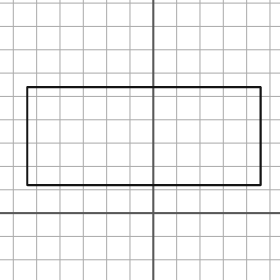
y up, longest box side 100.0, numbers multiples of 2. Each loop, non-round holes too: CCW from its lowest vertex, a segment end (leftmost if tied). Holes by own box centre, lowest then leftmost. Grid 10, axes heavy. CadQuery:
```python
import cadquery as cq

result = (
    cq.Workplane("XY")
    .moveTo(-54.0, 12.0)
    .lineTo(46.0, 12.0)
    .lineTo(46.0, 54.0)
    .lineTo(-54.0, 54.0)
    .close()
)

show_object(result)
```